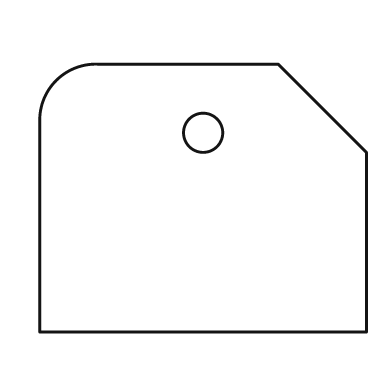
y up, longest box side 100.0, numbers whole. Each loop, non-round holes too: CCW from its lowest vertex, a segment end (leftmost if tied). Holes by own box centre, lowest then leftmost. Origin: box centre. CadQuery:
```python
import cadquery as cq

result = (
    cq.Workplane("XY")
    .moveTo(-50.0, -41.0)
    .lineTo(50.0, -41.0)
    .lineTo(50.0, 14.0)
    .lineTo(23.0, 41.0)
    .lineTo(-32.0, 41.0)
    .threePointArc((-45.0, 36.0), (-50.0, 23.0))
    .close()
    .moveTo(0.0, 20.0)
    .circle(6.0)
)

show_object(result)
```